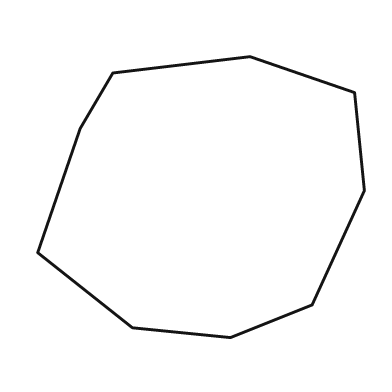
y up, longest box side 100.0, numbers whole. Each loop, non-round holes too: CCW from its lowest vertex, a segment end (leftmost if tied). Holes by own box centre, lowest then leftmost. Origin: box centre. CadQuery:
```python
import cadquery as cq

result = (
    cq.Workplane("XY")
    .moveTo(9.0, -43.0)
    .lineTo(34.0, -33.0)
    .lineTo(50.0, 2.0)
    .lineTo(47.0, 32.0)
    .lineTo(15.0, 43.0)
    .lineTo(-27.0, 38.0)
    .lineTo(-37.0, 21.0)
    .lineTo(-50.0, -17.0)
    .lineTo(-21.0, -40.0)
    .close()
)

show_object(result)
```